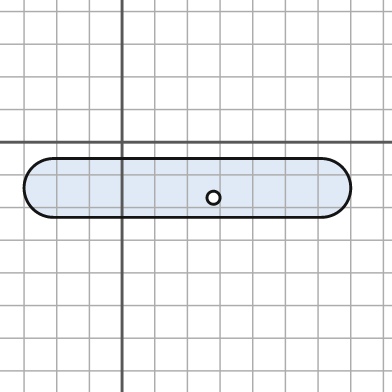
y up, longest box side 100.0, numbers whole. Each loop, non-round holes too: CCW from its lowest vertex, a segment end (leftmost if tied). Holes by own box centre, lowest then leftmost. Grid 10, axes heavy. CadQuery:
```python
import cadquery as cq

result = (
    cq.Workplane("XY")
    .moveTo(-21.0, -23.0)
    .lineTo(61.0, -23.0)
    .threePointArc((70.0, -14.0), (61.0, -5.0))
    .lineTo(-21.0, -5.0)
    .threePointArc((-30.0, -14.0), (-21.0, -23.0))
    .close()
    .moveTo(28.0, -17.0)
    .circle(2.0)
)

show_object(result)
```